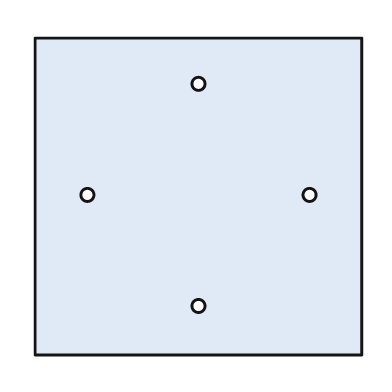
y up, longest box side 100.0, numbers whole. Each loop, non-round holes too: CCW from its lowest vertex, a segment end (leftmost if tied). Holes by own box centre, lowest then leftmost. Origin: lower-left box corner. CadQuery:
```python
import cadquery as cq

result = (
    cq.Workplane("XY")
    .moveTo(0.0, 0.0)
    .lineTo(100.0, 0.0)
    .lineTo(100.0, 97.0)
    .lineTo(0.0, 97.0)
    .close()
    .moveTo(50.0, 15.0)
    .circle(2.0)
    .moveTo(16.0, 49.0)
    .circle(2.0)
    .moveTo(84.0, 49.0)
    .circle(2.0)
    .moveTo(50.0, 83.0)
    .circle(2.0)
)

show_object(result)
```